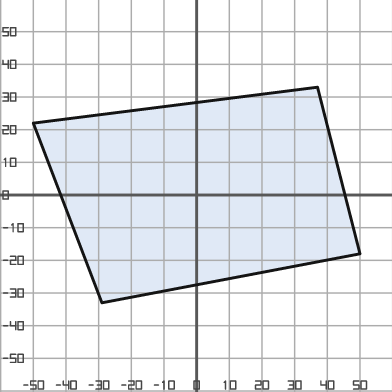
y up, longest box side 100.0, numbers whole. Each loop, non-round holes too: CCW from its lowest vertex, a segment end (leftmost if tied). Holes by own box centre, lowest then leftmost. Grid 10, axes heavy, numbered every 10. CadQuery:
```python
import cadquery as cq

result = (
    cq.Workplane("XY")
    .moveTo(-29.0, -33.0)
    .lineTo(50.0, -18.0)
    .lineTo(37.0, 33.0)
    .lineTo(-50.0, 22.0)
    .close()
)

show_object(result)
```